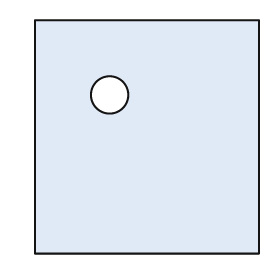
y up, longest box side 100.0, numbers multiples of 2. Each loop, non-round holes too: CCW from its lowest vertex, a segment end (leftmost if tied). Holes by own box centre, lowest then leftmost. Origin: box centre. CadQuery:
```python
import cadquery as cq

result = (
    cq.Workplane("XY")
    .moveTo(-48.0, -50.0)
    .lineTo(48.0, -50.0)
    .lineTo(48.0, 50.0)
    .lineTo(-48.0, 50.0)
    .close()
    .moveTo(-16.0, 18.0)
    .circle(8.0)
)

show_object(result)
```